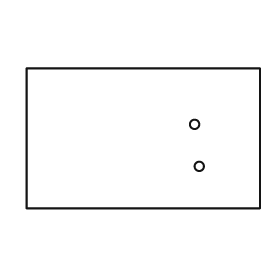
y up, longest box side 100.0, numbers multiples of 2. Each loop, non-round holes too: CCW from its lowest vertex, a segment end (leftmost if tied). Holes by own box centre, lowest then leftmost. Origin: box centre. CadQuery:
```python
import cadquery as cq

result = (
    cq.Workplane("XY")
    .moveTo(-50.0, -30.0)
    .lineTo(50.0, -30.0)
    .lineTo(50.0, 30.0)
    .lineTo(-50.0, 30.0)
    .close()
    .moveTo(24.0, -12.0)
    .circle(2.0)
    .moveTo(22.0, 6.0)
    .circle(2.0)
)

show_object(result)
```